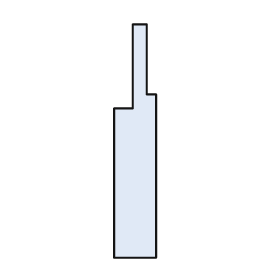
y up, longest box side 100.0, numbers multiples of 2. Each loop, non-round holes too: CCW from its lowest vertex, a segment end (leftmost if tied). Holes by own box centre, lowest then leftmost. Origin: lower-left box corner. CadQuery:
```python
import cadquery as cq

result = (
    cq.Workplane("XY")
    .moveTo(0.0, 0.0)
    .lineTo(18.0, 0.0)
    .lineTo(18.0, 70.0)
    .lineTo(14.0, 70.0)
    .lineTo(14.0, 100.0)
    .lineTo(8.0, 100.0)
    .lineTo(8.0, 64.0)
    .lineTo(0.0, 64.0)
    .close()
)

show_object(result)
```